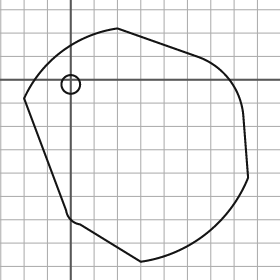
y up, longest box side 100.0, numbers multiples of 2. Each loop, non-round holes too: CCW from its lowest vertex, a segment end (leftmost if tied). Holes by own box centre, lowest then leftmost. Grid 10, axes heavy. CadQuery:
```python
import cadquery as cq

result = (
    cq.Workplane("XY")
    .moveTo(30.0, -78.0)
    .threePointArc((58.0, -66.0), (76.0, -42.0))
    .lineTo(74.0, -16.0)
    .threePointArc((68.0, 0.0), (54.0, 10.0))
    .lineTo(20.0, 22.0)
    .threePointArc((-4.0, 12.0), (-20.0, -8.0))
    .lineTo(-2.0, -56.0)
    .threePointArc((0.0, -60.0), (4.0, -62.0))
    .close()
    .moveTo(0.0, -2.0)
    .circle(4.0)
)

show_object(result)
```